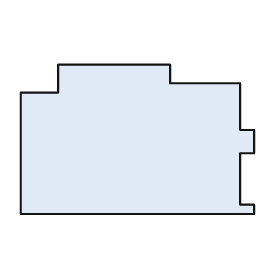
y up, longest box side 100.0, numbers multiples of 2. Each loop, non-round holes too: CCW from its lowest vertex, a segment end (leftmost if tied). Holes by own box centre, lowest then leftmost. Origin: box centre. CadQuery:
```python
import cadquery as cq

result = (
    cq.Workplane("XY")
    .moveTo(-50.0, -32.0)
    .lineTo(50.0, -32.0)
    .lineTo(50.0, -28.0)
    .lineTo(44.0, -28.0)
    .lineTo(44.0, -6.0)
    .lineTo(50.0, -6.0)
    .lineTo(50.0, 4.0)
    .lineTo(44.0, 4.0)
    .lineTo(44.0, 24.0)
    .lineTo(14.0, 24.0)
    .lineTo(14.0, 32.0)
    .lineTo(-34.0, 32.0)
    .lineTo(-34.0, 20.0)
    .lineTo(-50.0, 20.0)
    .close()
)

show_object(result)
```